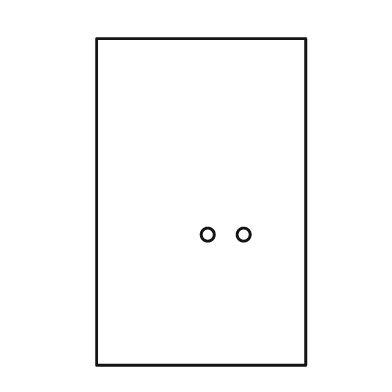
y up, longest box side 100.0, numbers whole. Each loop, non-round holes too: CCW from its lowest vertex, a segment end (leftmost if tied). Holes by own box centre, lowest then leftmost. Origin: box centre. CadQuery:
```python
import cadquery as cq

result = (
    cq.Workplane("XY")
    .moveTo(-32.0, -50.0)
    .lineTo(32.0, -50.0)
    .lineTo(32.0, 50.0)
    .lineTo(-32.0, 50.0)
    .close()
    .moveTo(2.0, -10.0)
    .circle(2.0)
    .moveTo(13.0, -10.0)
    .circle(2.0)
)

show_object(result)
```